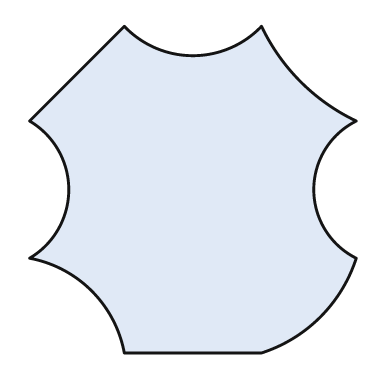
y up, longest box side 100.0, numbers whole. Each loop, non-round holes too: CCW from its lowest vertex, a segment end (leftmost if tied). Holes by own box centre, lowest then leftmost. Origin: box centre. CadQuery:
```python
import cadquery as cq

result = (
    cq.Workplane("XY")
    .moveTo(-21.0, -50.0)
    .lineTo(21.0, -50.0)
    .threePointArc((39.0, -39.0), (50.0, -21.0))
    .threePointArc((37.0, 0.0), (50.0, 21.0))
    .threePointArc((33.0, 33.0), (21.0, 50.0))
    .threePointArc((0.0, 41.0), (-21.0, 50.0))
    .lineTo(-50.0, 21.0)
    .threePointArc((-38.0, 0.0), (-50.0, -21.0))
    .threePointArc((-31.0, -31.0), (-21.0, -50.0))
    .close()
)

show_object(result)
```